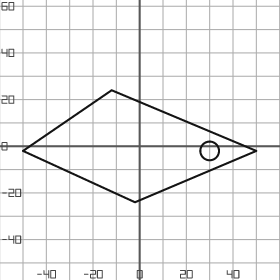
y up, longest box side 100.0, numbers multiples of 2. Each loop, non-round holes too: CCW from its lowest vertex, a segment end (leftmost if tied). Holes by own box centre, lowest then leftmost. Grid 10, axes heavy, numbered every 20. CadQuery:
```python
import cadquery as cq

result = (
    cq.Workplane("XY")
    .moveTo(-2.0, -24.0)
    .lineTo(50.0, -2.0)
    .lineTo(-12.0, 24.0)
    .lineTo(-50.0, -2.0)
    .close()
    .moveTo(30.0, -2.0)
    .circle(4.0)
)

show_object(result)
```